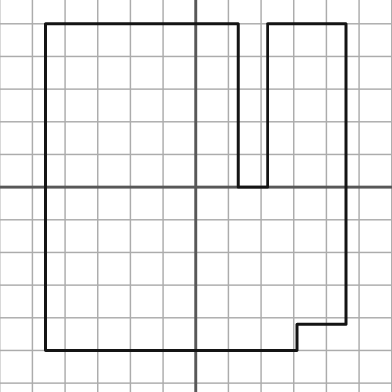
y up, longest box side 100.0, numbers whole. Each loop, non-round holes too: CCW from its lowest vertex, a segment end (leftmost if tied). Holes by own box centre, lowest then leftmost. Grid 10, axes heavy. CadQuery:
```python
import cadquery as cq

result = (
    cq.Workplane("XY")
    .moveTo(-46.0, -50.0)
    .lineTo(31.0, -50.0)
    .lineTo(31.0, -42.0)
    .lineTo(46.0, -42.0)
    .lineTo(46.0, 50.0)
    .lineTo(22.0, 50.0)
    .lineTo(22.0, 0.0)
    .lineTo(13.0, 0.0)
    .lineTo(13.0, 50.0)
    .lineTo(-46.0, 50.0)
    .close()
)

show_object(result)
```